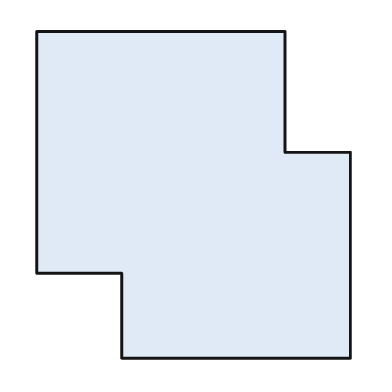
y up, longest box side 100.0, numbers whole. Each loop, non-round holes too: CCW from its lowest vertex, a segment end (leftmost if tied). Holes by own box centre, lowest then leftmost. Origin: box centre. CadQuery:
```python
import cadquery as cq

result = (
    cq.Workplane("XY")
    .moveTo(-22.0, -50.0)
    .lineTo(48.0, -50.0)
    .lineTo(48.0, 13.0)
    .lineTo(28.0, 13.0)
    .lineTo(28.0, 50.0)
    .lineTo(-48.0, 50.0)
    .lineTo(-48.0, -24.0)
    .lineTo(-22.0, -24.0)
    .close()
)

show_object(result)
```